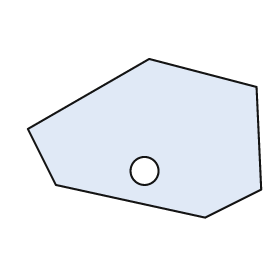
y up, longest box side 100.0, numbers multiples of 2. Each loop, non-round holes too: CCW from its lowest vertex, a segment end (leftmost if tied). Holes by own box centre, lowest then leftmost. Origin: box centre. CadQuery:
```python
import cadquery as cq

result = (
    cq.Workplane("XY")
    .moveTo(26.0, -34.0)
    .lineTo(50.0, -22.0)
    .lineTo(48.0, 22.0)
    .lineTo(2.0, 34.0)
    .lineTo(-50.0, 4.0)
    .lineTo(-38.0, -20.0)
    .close()
    .moveTo(0.0, -14.0)
    .circle(6.0)
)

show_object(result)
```